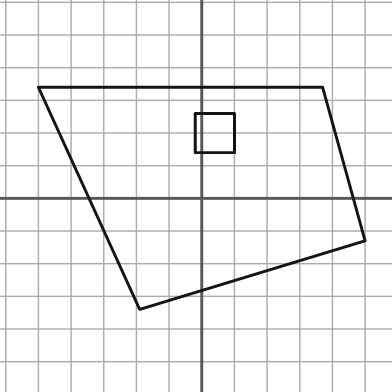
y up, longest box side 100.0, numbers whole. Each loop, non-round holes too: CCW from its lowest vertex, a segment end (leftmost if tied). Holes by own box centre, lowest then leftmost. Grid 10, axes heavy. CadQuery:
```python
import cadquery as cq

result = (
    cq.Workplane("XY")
    .moveTo(-19.0, -34.0)
    .lineTo(50.0, -13.0)
    .lineTo(37.0, 34.0)
    .lineTo(-50.0, 34.0)
    .close()
    .moveTo(-2.0, 14.0)
    .lineTo(10.0, 14.0)
    .lineTo(10.0, 26.0)
    .lineTo(-2.0, 26.0)
    .close()
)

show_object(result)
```